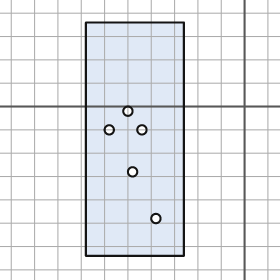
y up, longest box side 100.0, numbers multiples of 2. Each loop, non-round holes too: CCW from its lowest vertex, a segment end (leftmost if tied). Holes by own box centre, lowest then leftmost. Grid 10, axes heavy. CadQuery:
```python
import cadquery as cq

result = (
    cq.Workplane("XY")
    .moveTo(-68.0, -64.0)
    .lineTo(-26.0, -64.0)
    .lineTo(-26.0, 36.0)
    .lineTo(-68.0, 36.0)
    .close()
    .moveTo(-38.0, -48.0)
    .circle(2.0)
    .moveTo(-48.0, -28.0)
    .circle(2.0)
    .moveTo(-58.0, -10.0)
    .circle(2.0)
    .moveTo(-44.0, -10.0)
    .circle(2.0)
    .moveTo(-50.0, -2.0)
    .circle(2.0)
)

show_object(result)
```